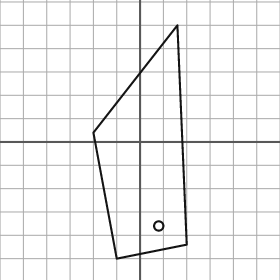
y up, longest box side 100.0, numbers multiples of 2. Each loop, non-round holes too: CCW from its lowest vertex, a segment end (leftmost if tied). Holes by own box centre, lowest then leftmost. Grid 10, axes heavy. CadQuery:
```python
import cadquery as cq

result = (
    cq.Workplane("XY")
    .moveTo(-10.0, -50.0)
    .lineTo(20.0, -44.0)
    .lineTo(16.0, 50.0)
    .lineTo(-20.0, 4.0)
    .close()
    .moveTo(8.0, -36.0)
    .circle(2.0)
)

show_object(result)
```